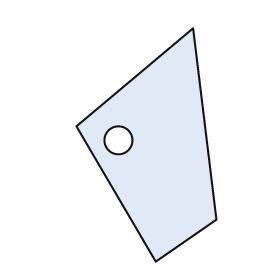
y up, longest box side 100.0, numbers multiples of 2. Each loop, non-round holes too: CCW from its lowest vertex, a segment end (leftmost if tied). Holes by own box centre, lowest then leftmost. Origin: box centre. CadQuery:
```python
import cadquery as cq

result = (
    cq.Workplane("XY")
    .moveTo(4.0, -50.0)
    .lineTo(30.0, -32.0)
    .lineTo(20.0, 50.0)
    .lineTo(-30.0, 8.0)
    .close()
    .moveTo(-12.0, 2.0)
    .circle(6.0)
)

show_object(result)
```